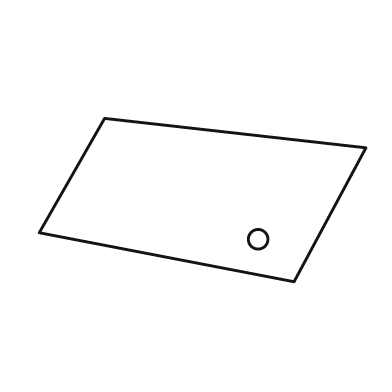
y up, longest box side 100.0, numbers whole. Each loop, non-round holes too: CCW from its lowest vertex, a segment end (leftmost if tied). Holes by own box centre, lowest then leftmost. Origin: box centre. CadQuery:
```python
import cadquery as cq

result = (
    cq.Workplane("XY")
    .moveTo(28.0, -25.0)
    .lineTo(50.0, 16.0)
    .lineTo(-30.0, 25.0)
    .lineTo(-50.0, -10.0)
    .close()
    .moveTo(17.0, -12.0)
    .circle(3.0)
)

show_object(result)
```